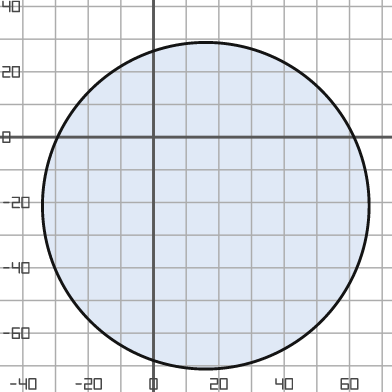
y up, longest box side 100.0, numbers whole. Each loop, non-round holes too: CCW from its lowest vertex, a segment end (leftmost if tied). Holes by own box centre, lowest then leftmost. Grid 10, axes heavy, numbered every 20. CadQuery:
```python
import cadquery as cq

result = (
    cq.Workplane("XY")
    .moveTo(16.0, -21.0)
    .circle(50.0)
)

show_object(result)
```